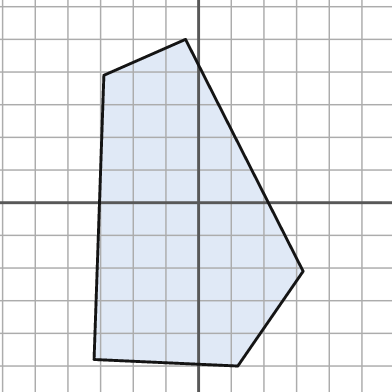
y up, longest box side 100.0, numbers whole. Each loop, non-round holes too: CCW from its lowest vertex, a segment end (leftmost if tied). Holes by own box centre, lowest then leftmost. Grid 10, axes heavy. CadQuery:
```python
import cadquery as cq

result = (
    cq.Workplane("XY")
    .moveTo(12.0, -50.0)
    .lineTo(32.0, -21.0)
    .lineTo(-4.0, 50.0)
    .lineTo(-29.0, 39.0)
    .lineTo(-32.0, -48.0)
    .close()
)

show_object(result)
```